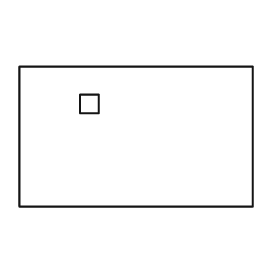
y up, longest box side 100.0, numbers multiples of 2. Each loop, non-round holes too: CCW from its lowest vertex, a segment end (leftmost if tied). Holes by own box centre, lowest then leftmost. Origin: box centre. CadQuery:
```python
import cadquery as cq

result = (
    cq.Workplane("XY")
    .moveTo(-50.0, -30.0)
    .lineTo(50.0, -30.0)
    .lineTo(50.0, 30.0)
    .lineTo(-50.0, 30.0)
    .close()
    .moveTo(-24.0, 10.0)
    .lineTo(-16.0, 10.0)
    .lineTo(-16.0, 18.0)
    .lineTo(-24.0, 18.0)
    .close()
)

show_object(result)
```